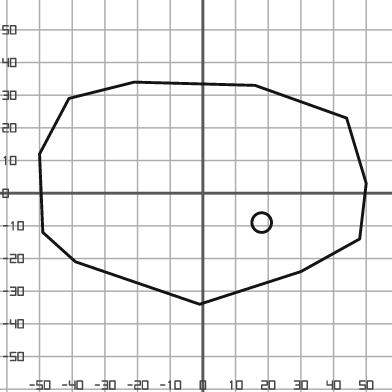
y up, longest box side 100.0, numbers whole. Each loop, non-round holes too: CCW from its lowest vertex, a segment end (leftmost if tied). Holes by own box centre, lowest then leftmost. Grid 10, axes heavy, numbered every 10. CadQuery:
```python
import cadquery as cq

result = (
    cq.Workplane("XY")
    .moveTo(-1.0, -34.0)
    .lineTo(30.0, -24.0)
    .lineTo(48.0, -14.0)
    .lineTo(50.0, 3.0)
    .lineTo(44.0, 23.0)
    .lineTo(16.0, 33.0)
    .lineTo(-21.0, 34.0)
    .lineTo(-41.0, 29.0)
    .lineTo(-50.0, 12.0)
    .lineTo(-49.0, -12.0)
    .lineTo(-39.0, -21.0)
    .close()
    .moveTo(18.0, -9.0)
    .circle(3.0)
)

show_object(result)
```